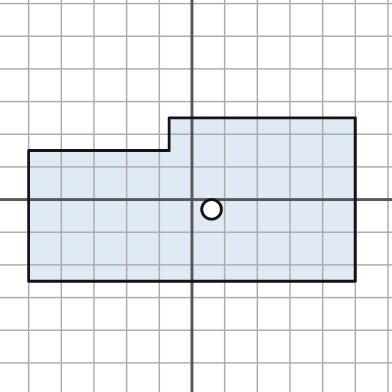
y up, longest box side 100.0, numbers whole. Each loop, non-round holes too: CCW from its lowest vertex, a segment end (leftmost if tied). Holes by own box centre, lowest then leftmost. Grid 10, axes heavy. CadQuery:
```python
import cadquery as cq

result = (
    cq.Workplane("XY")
    .moveTo(-50.0, -25.0)
    .lineTo(50.0, -25.0)
    .lineTo(50.0, 25.0)
    .lineTo(-7.0, 25.0)
    .lineTo(-7.0, 15.0)
    .lineTo(-50.0, 15.0)
    .close()
    .moveTo(6.0, -3.0)
    .circle(3.0)
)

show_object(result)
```